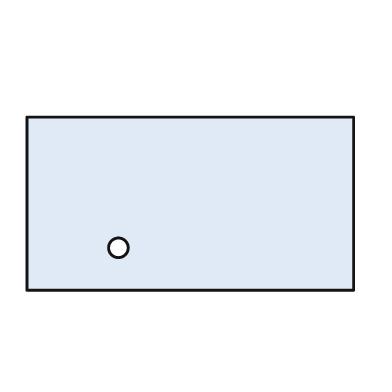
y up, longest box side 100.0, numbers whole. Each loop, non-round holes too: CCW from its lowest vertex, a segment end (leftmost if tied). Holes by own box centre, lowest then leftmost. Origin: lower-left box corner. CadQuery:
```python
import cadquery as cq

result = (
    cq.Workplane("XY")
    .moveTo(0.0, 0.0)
    .lineTo(100.0, 0.0)
    .lineTo(100.0, 53.0)
    .lineTo(0.0, 53.0)
    .close()
    .moveTo(28.0, 13.0)
    .circle(3.0)
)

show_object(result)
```